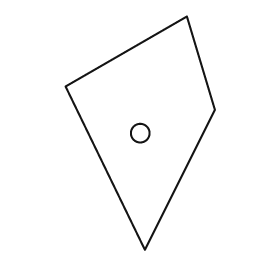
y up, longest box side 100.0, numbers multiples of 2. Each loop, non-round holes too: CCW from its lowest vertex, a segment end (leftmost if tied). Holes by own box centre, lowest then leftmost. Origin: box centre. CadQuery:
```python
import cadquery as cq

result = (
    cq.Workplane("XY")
    .moveTo(2.0, -50.0)
    .lineTo(32.0, 10.0)
    .lineTo(20.0, 50.0)
    .lineTo(-32.0, 20.0)
    .close()
    .moveTo(0.0, 0.0)
    .circle(4.0)
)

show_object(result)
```